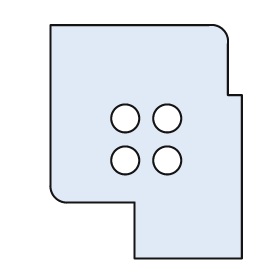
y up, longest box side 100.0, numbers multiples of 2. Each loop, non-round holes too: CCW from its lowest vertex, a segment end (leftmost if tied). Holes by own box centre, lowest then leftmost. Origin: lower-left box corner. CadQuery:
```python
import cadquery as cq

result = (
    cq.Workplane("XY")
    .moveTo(36.0, 0.0)
    .lineTo(82.0, 0.0)
    .lineTo(82.0, 70.0)
    .lineTo(76.0, 70.0)
    .lineTo(76.0, 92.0)
    .threePointArc((74.0, 98.0), (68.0, 100.0))
    .lineTo(0.0, 100.0)
    .lineTo(0.0, 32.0)
    .threePointArc((2.0, 26.0), (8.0, 24.0))
    .lineTo(36.0, 24.0)
    .close()
    .moveTo(32.0, 42.0)
    .circle(6.0)
    .moveTo(50.0, 42.0)
    .circle(6.0)
    .moveTo(32.0, 60.0)
    .circle(6.0)
    .moveTo(50.0, 60.0)
    .circle(6.0)
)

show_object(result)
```